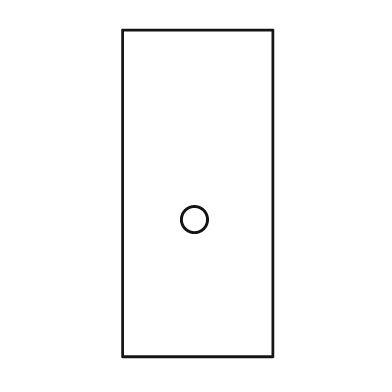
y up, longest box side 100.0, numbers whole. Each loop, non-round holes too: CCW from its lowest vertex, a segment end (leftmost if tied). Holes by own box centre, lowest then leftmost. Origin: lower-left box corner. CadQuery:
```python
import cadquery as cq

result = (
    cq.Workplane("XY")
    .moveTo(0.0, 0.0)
    .lineTo(46.0, 0.0)
    .lineTo(46.0, 100.0)
    .lineTo(0.0, 100.0)
    .close()
    .moveTo(22.0, 42.0)
    .circle(4.0)
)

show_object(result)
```